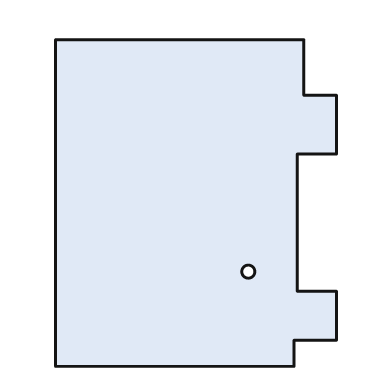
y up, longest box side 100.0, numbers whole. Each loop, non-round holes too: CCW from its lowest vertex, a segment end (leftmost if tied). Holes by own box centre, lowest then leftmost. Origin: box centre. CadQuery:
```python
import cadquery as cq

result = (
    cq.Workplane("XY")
    .moveTo(-43.0, -50.0)
    .lineTo(30.0, -50.0)
    .lineTo(30.0, -42.0)
    .lineTo(43.0, -42.0)
    .lineTo(43.0, -27.0)
    .lineTo(31.0, -27.0)
    .lineTo(31.0, 15.0)
    .lineTo(43.0, 15.0)
    .lineTo(43.0, 33.0)
    .lineTo(33.0, 33.0)
    .lineTo(33.0, 50.0)
    .lineTo(-43.0, 50.0)
    .close()
    .moveTo(16.0, -21.0)
    .circle(2.0)
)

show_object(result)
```